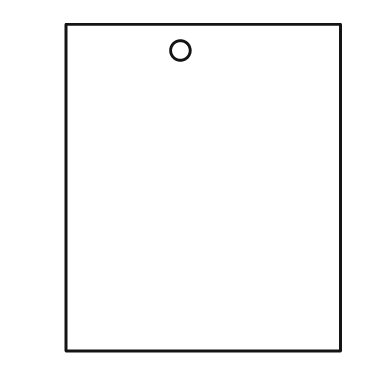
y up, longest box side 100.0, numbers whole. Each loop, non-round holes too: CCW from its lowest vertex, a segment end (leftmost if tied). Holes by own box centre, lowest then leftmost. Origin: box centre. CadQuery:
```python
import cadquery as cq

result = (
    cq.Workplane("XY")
    .moveTo(-42.0, -50.0)
    .lineTo(42.0, -50.0)
    .lineTo(42.0, 50.0)
    .lineTo(-42.0, 50.0)
    .close()
    .moveTo(-7.0, 42.0)
    .circle(3.0)
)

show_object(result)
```